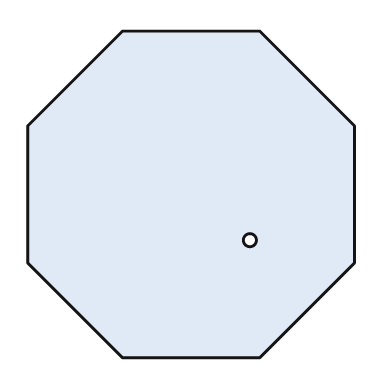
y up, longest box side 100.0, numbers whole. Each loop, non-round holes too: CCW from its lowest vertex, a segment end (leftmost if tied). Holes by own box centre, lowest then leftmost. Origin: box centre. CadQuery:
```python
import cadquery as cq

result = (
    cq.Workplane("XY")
    .moveTo(-21.0, -50.0)
    .lineTo(21.0, -50.0)
    .lineTo(50.0, -21.0)
    .lineTo(50.0, 21.0)
    .lineTo(21.0, 50.0)
    .lineTo(-21.0, 50.0)
    .lineTo(-50.0, 21.0)
    .lineTo(-50.0, -21.0)
    .close()
    .moveTo(18.0, -14.0)
    .circle(2.0)
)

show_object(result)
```